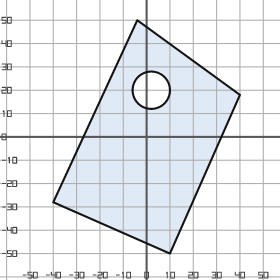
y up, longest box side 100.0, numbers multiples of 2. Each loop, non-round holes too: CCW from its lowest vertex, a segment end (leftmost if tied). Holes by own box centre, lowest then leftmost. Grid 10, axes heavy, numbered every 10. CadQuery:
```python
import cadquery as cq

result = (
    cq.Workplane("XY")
    .moveTo(10.0, -50.0)
    .lineTo(40.0, 18.0)
    .lineTo(-4.0, 50.0)
    .lineTo(-40.0, -28.0)
    .close()
    .moveTo(2.0, 20.0)
    .circle(8.0)
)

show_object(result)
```